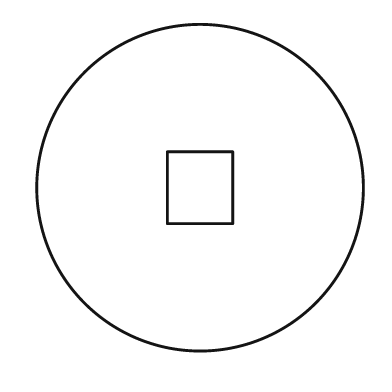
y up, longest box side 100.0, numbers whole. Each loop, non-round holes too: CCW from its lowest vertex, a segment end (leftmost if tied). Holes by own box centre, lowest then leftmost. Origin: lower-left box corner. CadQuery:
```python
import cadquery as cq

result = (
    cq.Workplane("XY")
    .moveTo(50.0, 50.0)
    .circle(50.0)
    .moveTo(40.0, 39.0)
    .lineTo(60.0, 39.0)
    .lineTo(60.0, 61.0)
    .lineTo(40.0, 61.0)
    .close()
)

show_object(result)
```